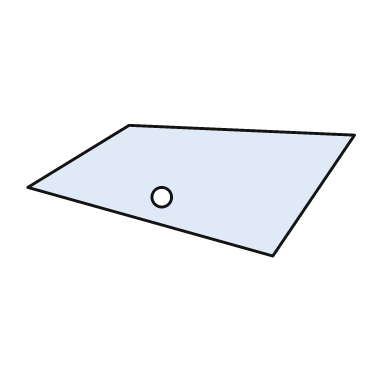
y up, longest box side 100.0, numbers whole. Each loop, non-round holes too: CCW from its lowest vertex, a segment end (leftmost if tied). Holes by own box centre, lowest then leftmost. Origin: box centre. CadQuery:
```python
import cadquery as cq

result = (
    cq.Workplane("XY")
    .moveTo(25.0, -20.0)
    .lineTo(50.0, 17.0)
    .lineTo(-19.0, 20.0)
    .lineTo(-50.0, 1.0)
    .close()
    .moveTo(-9.0, -2.0)
    .circle(3.0)
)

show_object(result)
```